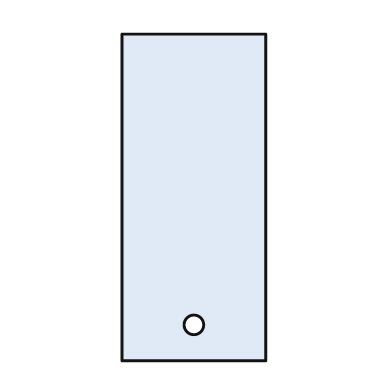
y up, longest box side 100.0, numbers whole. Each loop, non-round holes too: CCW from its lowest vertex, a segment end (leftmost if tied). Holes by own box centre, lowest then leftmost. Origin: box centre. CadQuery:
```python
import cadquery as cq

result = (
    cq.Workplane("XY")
    .moveTo(-22.0, -50.0)
    .lineTo(22.0, -50.0)
    .lineTo(22.0, 50.0)
    .lineTo(-22.0, 50.0)
    .close()
    .moveTo(0.0, -39.0)
    .circle(3.0)
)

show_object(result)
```